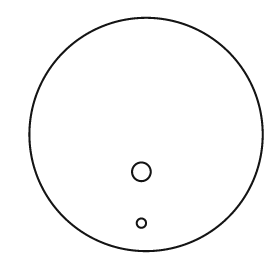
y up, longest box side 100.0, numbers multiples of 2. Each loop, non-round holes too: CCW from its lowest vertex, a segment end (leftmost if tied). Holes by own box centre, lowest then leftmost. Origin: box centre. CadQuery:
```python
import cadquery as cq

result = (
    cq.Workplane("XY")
    .moveTo(0.0, 0.0)
    .circle(50.0)
    .moveTo(-2.0, -38.0)
    .circle(2.0)
    .moveTo(-2.0, -16.0)
    .circle(4.0)
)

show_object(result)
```